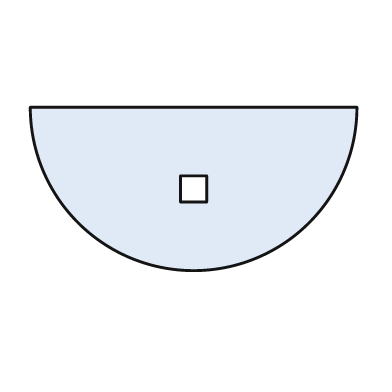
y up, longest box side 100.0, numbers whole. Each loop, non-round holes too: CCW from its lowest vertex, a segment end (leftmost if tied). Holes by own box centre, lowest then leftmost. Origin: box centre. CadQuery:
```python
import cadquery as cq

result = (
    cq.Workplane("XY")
    .moveTo(-50.0, 25.0)
    .threePointArc((0.0, -25.0), (50.0, 25.0))
    .close()
    .moveTo(-4.0, -4.0)
    .lineTo(4.0, -4.0)
    .lineTo(4.0, 4.0)
    .lineTo(-4.0, 4.0)
    .close()
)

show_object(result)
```